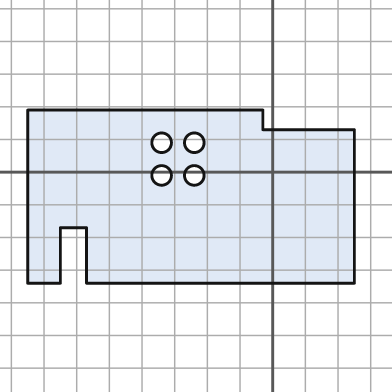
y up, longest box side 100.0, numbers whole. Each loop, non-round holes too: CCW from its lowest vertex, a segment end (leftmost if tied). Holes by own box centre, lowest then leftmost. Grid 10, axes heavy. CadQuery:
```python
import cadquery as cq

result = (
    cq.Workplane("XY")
    .moveTo(-75.0, -34.0)
    .lineTo(-65.0, -34.0)
    .lineTo(-65.0, -17.0)
    .lineTo(-57.0, -17.0)
    .lineTo(-57.0, -34.0)
    .lineTo(25.0, -34.0)
    .lineTo(25.0, 13.0)
    .lineTo(-3.0, 13.0)
    .lineTo(-3.0, 19.0)
    .lineTo(-75.0, 19.0)
    .close()
    .moveTo(-34.0, -1.0)
    .circle(3.0)
    .moveTo(-24.0, -1.0)
    .circle(3.0)
    .moveTo(-34.0, 9.0)
    .circle(3.0)
    .moveTo(-24.0, 9.0)
    .circle(3.0)
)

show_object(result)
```